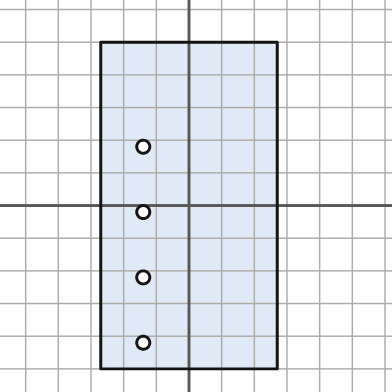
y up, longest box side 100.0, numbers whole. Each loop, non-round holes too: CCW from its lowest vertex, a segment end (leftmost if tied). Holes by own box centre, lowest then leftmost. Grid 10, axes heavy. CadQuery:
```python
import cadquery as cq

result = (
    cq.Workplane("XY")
    .moveTo(-27.0, -50.0)
    .lineTo(27.0, -50.0)
    .lineTo(27.0, 50.0)
    .lineTo(-27.0, 50.0)
    .close()
    .moveTo(-14.0, -42.0)
    .circle(2.0)
    .moveTo(-14.0, -22.0)
    .circle(2.0)
    .moveTo(-14.0, -2.0)
    .circle(2.0)
    .moveTo(-14.0, 18.0)
    .circle(2.0)
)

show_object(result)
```